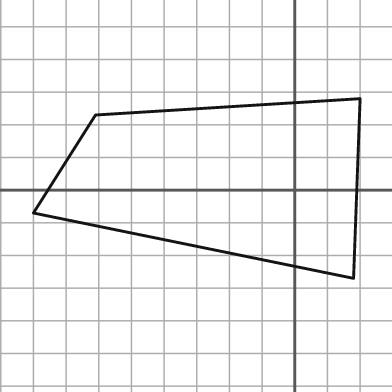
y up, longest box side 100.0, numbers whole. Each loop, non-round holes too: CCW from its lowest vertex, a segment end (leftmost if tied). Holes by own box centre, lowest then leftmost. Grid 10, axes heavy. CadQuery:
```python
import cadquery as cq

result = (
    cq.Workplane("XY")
    .moveTo(18.0, -27.0)
    .lineTo(20.0, 28.0)
    .lineTo(-61.0, 23.0)
    .lineTo(-80.0, -7.0)
    .close()
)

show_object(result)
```